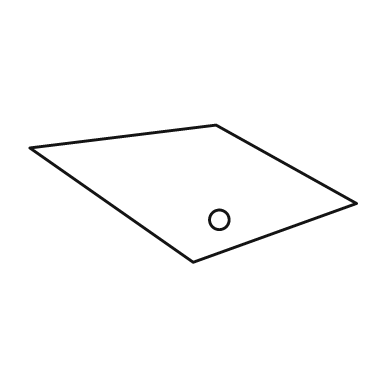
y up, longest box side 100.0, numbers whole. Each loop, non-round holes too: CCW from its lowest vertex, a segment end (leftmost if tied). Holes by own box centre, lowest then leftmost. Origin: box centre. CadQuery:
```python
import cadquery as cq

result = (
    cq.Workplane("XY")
    .moveTo(0.0, -21.0)
    .lineTo(50.0, -3.0)
    .lineTo(7.0, 21.0)
    .lineTo(-50.0, 14.0)
    .close()
    .moveTo(8.0, -8.0)
    .circle(3.0)
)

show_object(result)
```